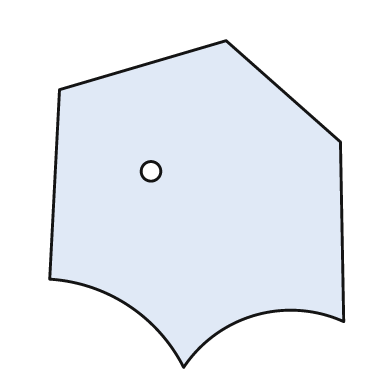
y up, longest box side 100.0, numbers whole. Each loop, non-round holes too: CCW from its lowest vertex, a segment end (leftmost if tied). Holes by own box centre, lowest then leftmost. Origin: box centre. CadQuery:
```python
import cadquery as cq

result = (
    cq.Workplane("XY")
    .moveTo(-4.0, -50.0)
    .threePointArc((18.0, -34.0), (45.0, -36.0))
    .lineTo(44.0, 19.0)
    .lineTo(9.0, 50.0)
    .lineTo(-42.0, 35.0)
    .lineTo(-45.0, -23.0)
    .threePointArc((-21.0, -31.0), (-4.0, -50.0))
    .close()
    .moveTo(-14.0, 10.0)
    .circle(3.0)
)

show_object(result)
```